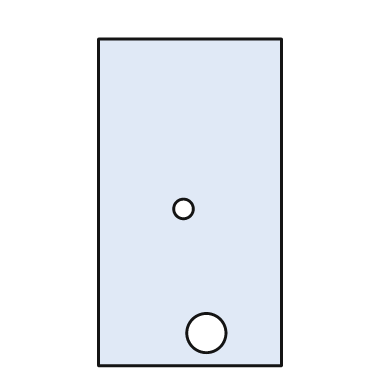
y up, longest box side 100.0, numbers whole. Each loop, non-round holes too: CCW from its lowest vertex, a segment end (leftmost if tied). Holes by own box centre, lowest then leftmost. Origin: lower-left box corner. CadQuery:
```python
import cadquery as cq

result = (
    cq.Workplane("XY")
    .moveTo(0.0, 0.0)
    .lineTo(56.0, 0.0)
    .lineTo(56.0, 100.0)
    .lineTo(0.0, 100.0)
    .close()
    .moveTo(33.0, 10.0)
    .circle(6.0)
    .moveTo(26.0, 48.0)
    .circle(3.0)
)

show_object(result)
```